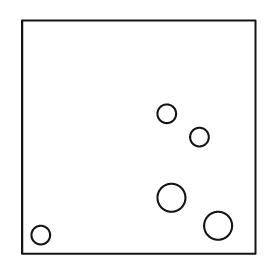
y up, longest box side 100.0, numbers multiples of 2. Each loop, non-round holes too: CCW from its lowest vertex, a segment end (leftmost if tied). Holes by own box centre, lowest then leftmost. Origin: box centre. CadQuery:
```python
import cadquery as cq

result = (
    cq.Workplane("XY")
    .moveTo(-50.0, -50.0)
    .lineTo(50.0, -50.0)
    .lineTo(50.0, 50.0)
    .lineTo(-50.0, 50.0)
    .close()
    .moveTo(-42.0, -42.0)
    .circle(4.0)
    .moveTo(34.0, -38.0)
    .circle(6.0)
    .moveTo(14.0, -26.0)
    .circle(6.0)
    .moveTo(26.0, 0.0)
    .circle(4.0)
    .moveTo(12.0, 10.0)
    .circle(4.0)
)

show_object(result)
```